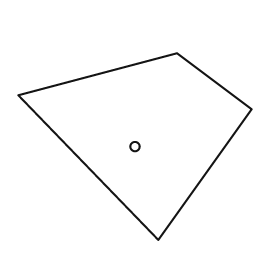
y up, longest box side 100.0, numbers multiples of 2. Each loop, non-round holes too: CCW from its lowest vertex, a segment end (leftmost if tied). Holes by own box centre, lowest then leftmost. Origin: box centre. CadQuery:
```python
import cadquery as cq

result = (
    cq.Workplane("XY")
    .moveTo(10.0, -40.0)
    .lineTo(50.0, 16.0)
    .lineTo(18.0, 40.0)
    .lineTo(-50.0, 22.0)
    .close()
    .moveTo(0.0, 0.0)
    .circle(2.0)
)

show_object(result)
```